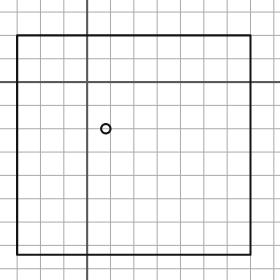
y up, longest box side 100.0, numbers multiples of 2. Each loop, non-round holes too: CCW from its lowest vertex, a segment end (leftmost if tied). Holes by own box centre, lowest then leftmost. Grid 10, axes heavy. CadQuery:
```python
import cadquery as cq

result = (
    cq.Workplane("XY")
    .moveTo(-30.0, -74.0)
    .lineTo(70.0, -74.0)
    .lineTo(70.0, 20.0)
    .lineTo(-30.0, 20.0)
    .close()
    .moveTo(8.0, -20.0)
    .circle(2.0)
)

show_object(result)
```